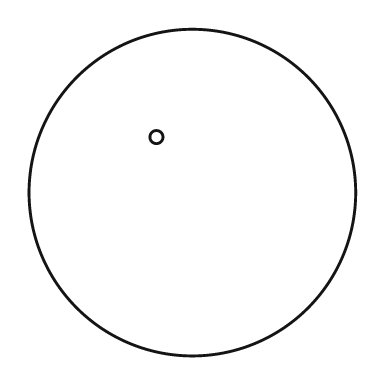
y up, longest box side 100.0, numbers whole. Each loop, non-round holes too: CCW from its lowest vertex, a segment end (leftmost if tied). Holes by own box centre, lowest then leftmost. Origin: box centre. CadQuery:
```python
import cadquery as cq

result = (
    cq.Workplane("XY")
    .moveTo(0.0, 0.0)
    .circle(50.0)
    .moveTo(-11.0, 17.0)
    .circle(2.0)
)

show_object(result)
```